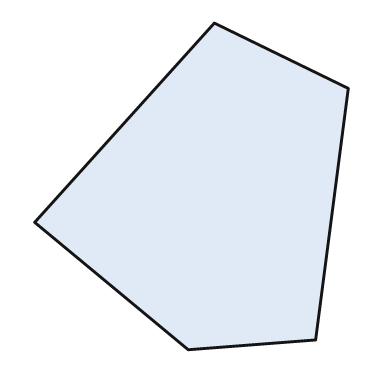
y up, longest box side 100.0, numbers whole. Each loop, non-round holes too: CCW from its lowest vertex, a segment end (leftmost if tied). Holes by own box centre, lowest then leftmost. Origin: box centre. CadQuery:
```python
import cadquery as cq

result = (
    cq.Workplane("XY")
    .moveTo(-1.0, -50.0)
    .lineTo(38.0, -47.0)
    .lineTo(48.0, 30.0)
    .lineTo(7.0, 50.0)
    .lineTo(-48.0, -11.0)
    .close()
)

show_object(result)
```